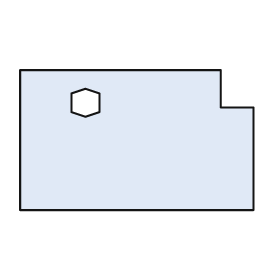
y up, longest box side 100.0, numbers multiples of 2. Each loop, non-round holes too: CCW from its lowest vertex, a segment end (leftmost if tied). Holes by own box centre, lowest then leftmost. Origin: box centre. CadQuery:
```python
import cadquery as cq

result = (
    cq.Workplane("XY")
    .moveTo(-50.0, -30.0)
    .lineTo(50.0, -30.0)
    .lineTo(50.0, 14.0)
    .lineTo(36.0, 14.0)
    .lineTo(36.0, 30.0)
    .lineTo(-50.0, 30.0)
    .close()
    .moveTo(-22.0, 10.0)
    .lineTo(-16.0, 12.0)
    .lineTo(-16.0, 20.0)
    .lineTo(-22.0, 22.0)
    .lineTo(-28.0, 20.0)
    .lineTo(-28.0, 12.0)
    .close()
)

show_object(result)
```